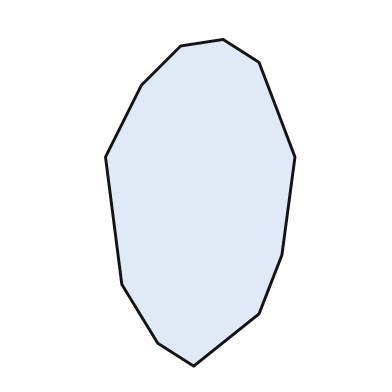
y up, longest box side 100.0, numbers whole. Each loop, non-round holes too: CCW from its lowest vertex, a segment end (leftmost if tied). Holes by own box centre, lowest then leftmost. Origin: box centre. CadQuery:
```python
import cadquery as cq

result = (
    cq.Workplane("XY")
    .moveTo(-2.0, -50.0)
    .lineTo(18.0, -34.0)
    .lineTo(25.0, -16.0)
    .lineTo(29.0, 14.0)
    .lineTo(18.0, 43.0)
    .lineTo(7.0, 50.0)
    .lineTo(-6.0, 48.0)
    .lineTo(-18.0, 36.0)
    .lineTo(-29.0, 14.0)
    .lineTo(-24.0, -25.0)
    .lineTo(-13.0, -43.0)
    .close()
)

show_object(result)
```